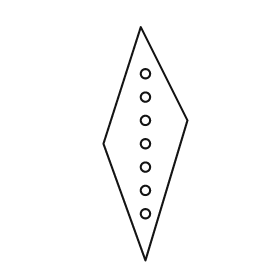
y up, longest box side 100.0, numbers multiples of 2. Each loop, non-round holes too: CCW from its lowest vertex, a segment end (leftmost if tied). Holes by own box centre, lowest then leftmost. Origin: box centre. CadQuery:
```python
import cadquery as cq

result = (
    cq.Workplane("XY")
    .moveTo(0.0, -50.0)
    .lineTo(18.0, 10.0)
    .lineTo(-2.0, 50.0)
    .lineTo(-18.0, 0.0)
    .close()
    .moveTo(0.0, -30.0)
    .circle(2.0)
    .moveTo(0.0, -20.0)
    .circle(2.0)
    .moveTo(0.0, -10.0)
    .circle(2.0)
    .moveTo(0.0, 0.0)
    .circle(2.0)
    .moveTo(0.0, 10.0)
    .circle(2.0)
    .moveTo(0.0, 20.0)
    .circle(2.0)
    .moveTo(0.0, 30.0)
    .circle(2.0)
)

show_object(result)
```